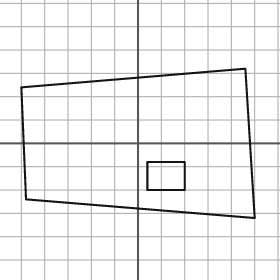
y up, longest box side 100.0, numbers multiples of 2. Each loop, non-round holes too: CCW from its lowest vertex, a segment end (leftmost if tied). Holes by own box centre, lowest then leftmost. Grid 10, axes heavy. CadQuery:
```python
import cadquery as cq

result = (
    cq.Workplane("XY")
    .moveTo(50.0, -32.0)
    .lineTo(46.0, 32.0)
    .lineTo(-50.0, 24.0)
    .lineTo(-48.0, -24.0)
    .close()
    .moveTo(4.0, -20.0)
    .lineTo(20.0, -20.0)
    .lineTo(20.0, -8.0)
    .lineTo(4.0, -8.0)
    .close()
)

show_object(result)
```